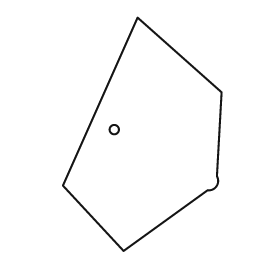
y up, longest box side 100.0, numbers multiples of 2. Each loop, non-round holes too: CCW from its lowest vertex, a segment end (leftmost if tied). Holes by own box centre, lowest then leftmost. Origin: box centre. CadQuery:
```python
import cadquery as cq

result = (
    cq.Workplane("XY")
    .moveTo(-8.0, -50.0)
    .lineTo(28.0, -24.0)
    .threePointArc((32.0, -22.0), (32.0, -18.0))
    .lineTo(34.0, 18.0)
    .lineTo(-2.0, 50.0)
    .lineTo(-34.0, -22.0)
    .close()
    .moveTo(-12.0, 2.0)
    .circle(2.0)
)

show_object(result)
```